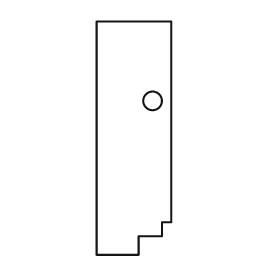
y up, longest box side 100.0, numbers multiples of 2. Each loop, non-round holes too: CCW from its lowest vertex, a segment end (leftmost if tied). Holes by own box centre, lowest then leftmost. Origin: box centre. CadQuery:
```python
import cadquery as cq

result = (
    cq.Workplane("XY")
    .moveTo(-16.0, -50.0)
    .lineTo(2.0, -50.0)
    .lineTo(2.0, -42.0)
    .lineTo(12.0, -42.0)
    .lineTo(12.0, -36.0)
    .lineTo(16.0, -36.0)
    .lineTo(16.0, 50.0)
    .lineTo(-16.0, 50.0)
    .close()
    .moveTo(8.0, 16.0)
    .circle(4.0)
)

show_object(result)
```